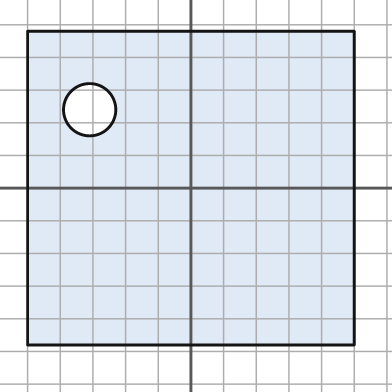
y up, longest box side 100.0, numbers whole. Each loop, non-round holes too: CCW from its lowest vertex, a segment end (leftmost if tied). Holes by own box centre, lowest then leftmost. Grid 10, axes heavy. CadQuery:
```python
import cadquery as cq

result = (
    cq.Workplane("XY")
    .moveTo(-50.0, -48.0)
    .lineTo(50.0, -48.0)
    .lineTo(50.0, 48.0)
    .lineTo(-50.0, 48.0)
    .close()
    .moveTo(-31.0, 24.0)
    .circle(8.0)
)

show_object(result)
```